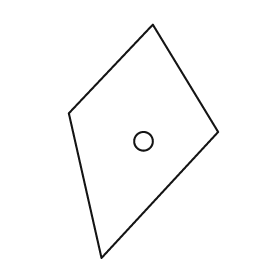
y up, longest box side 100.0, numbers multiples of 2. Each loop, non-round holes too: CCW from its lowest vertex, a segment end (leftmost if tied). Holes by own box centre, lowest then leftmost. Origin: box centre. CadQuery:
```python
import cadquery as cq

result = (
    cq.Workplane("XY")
    .moveTo(-18.0, -50.0)
    .lineTo(32.0, 4.0)
    .lineTo(4.0, 50.0)
    .lineTo(-32.0, 12.0)
    .close()
    .moveTo(0.0, 0.0)
    .circle(4.0)
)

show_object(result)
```